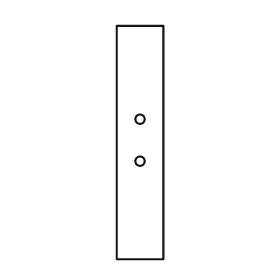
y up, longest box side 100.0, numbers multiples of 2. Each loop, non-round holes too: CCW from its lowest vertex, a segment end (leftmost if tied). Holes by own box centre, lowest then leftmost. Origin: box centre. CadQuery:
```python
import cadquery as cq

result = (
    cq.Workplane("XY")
    .moveTo(-10.0, -50.0)
    .lineTo(10.0, -50.0)
    .lineTo(10.0, 50.0)
    .lineTo(-10.0, 50.0)
    .close()
    .moveTo(0.0, -8.0)
    .circle(2.0)
    .moveTo(0.0, 10.0)
    .circle(2.0)
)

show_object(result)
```